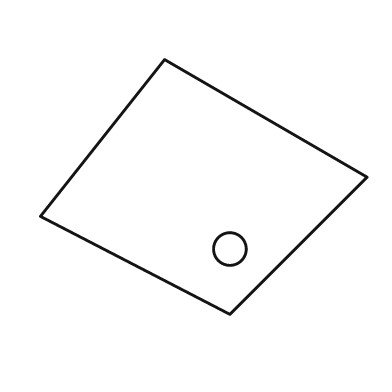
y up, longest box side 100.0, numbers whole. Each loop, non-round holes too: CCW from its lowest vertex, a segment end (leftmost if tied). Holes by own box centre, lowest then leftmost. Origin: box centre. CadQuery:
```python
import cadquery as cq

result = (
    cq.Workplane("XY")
    .moveTo(8.0, -39.0)
    .lineTo(50.0, 3.0)
    .lineTo(-12.0, 39.0)
    .lineTo(-50.0, -9.0)
    .close()
    .moveTo(8.0, -19.0)
    .circle(5.0)
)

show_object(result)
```